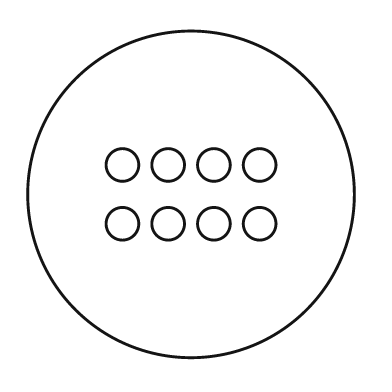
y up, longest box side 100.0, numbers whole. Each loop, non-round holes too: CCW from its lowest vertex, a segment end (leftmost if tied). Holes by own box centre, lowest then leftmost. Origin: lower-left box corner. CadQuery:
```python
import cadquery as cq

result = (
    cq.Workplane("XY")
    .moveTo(50.0, 50.0)
    .circle(50.0)
    .moveTo(29.0, 41.0)
    .circle(5.0)
    .moveTo(43.0, 41.0)
    .circle(5.0)
    .moveTo(57.0, 41.0)
    .circle(5.0)
    .moveTo(71.0, 41.0)
    .circle(5.0)
    .moveTo(29.0, 59.0)
    .circle(5.0)
    .moveTo(43.0, 59.0)
    .circle(5.0)
    .moveTo(57.0, 59.0)
    .circle(5.0)
    .moveTo(71.0, 59.0)
    .circle(5.0)
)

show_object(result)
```